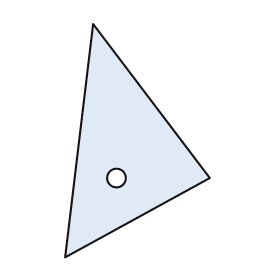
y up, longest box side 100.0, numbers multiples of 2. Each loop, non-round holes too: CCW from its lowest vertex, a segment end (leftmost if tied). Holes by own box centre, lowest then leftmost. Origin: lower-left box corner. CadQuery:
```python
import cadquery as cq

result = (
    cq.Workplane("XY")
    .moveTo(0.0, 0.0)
    .lineTo(62.0, 34.0)
    .lineTo(12.0, 100.0)
    .close()
    .moveTo(22.0, 34.0)
    .circle(4.0)
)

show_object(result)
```